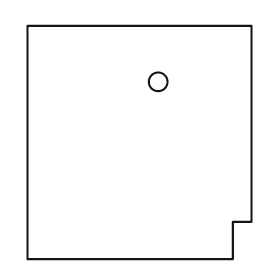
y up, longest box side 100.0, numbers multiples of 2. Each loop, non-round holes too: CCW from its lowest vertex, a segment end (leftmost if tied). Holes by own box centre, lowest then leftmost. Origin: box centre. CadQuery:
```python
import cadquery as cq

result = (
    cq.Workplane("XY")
    .moveTo(-48.0, -50.0)
    .lineTo(40.0, -50.0)
    .lineTo(40.0, -34.0)
    .lineTo(48.0, -34.0)
    .lineTo(48.0, 50.0)
    .lineTo(-48.0, 50.0)
    .close()
    .moveTo(8.0, 26.0)
    .circle(4.0)
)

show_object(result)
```